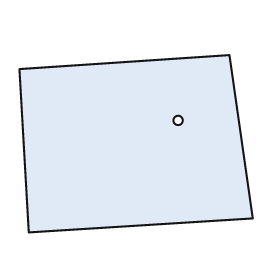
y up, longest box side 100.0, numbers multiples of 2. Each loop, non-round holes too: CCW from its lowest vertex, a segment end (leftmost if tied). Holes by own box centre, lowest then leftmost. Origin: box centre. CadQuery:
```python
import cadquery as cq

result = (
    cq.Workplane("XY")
    .moveTo(-46.0, -38.0)
    .lineTo(50.0, -32.0)
    .lineTo(40.0, 38.0)
    .lineTo(-50.0, 32.0)
    .close()
    .moveTo(18.0, 10.0)
    .circle(2.0)
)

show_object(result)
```